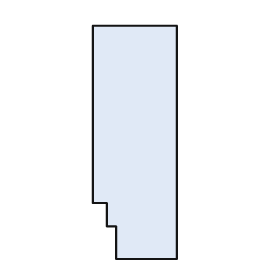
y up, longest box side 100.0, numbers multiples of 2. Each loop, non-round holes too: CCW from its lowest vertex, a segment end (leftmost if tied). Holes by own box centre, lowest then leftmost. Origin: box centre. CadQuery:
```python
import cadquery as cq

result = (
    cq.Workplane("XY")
    .moveTo(-8.0, -50.0)
    .lineTo(18.0, -50.0)
    .lineTo(18.0, 50.0)
    .lineTo(-18.0, 50.0)
    .lineTo(-18.0, -26.0)
    .lineTo(-12.0, -26.0)
    .lineTo(-12.0, -36.0)
    .lineTo(-8.0, -36.0)
    .close()
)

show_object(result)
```